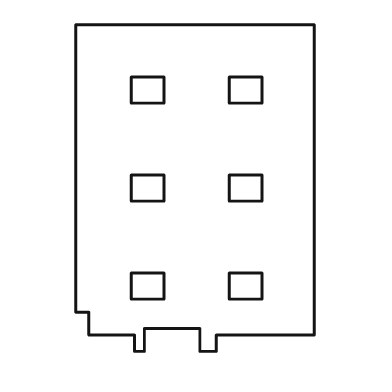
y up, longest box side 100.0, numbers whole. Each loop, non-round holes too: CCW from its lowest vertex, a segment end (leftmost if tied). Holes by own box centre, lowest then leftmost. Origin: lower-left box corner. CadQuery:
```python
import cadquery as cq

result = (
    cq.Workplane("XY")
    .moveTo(18.0, 0.0)
    .lineTo(21.0, 0.0)
    .lineTo(21.0, 7.0)
    .lineTo(38.0, 7.0)
    .lineTo(38.0, 0.0)
    .lineTo(43.0, 0.0)
    .lineTo(43.0, 5.0)
    .lineTo(73.0, 5.0)
    .lineTo(73.0, 100.0)
    .lineTo(0.0, 100.0)
    .lineTo(0.0, 12.0)
    .lineTo(4.0, 12.0)
    .lineTo(4.0, 5.0)
    .lineTo(18.0, 5.0)
    .close()
    .moveTo(17.0, 16.0)
    .lineTo(27.0, 16.0)
    .lineTo(27.0, 24.0)
    .lineTo(17.0, 24.0)
    .close()
    .moveTo(47.0, 16.0)
    .lineTo(57.0, 16.0)
    .lineTo(57.0, 24.0)
    .lineTo(47.0, 24.0)
    .close()
    .moveTo(17.0, 46.0)
    .lineTo(27.0, 46.0)
    .lineTo(27.0, 54.0)
    .lineTo(17.0, 54.0)
    .close()
    .moveTo(47.0, 46.0)
    .lineTo(57.0, 46.0)
    .lineTo(57.0, 54.0)
    .lineTo(47.0, 54.0)
    .close()
    .moveTo(17.0, 76.0)
    .lineTo(27.0, 76.0)
    .lineTo(27.0, 84.0)
    .lineTo(17.0, 84.0)
    .close()
    .moveTo(47.0, 76.0)
    .lineTo(57.0, 76.0)
    .lineTo(57.0, 84.0)
    .lineTo(47.0, 84.0)
    .close()
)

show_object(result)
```